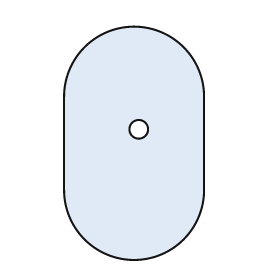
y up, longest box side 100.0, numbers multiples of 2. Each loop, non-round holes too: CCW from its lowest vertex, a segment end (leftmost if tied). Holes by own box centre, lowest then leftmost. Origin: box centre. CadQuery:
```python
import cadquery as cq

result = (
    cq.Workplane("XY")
    .moveTo(-30.0, -20.0)
    .threePointArc((0.0, -50.0), (30.0, -20.0))
    .lineTo(30.0, 20.0)
    .threePointArc((0.0, 50.0), (-30.0, 20.0))
    .close()
    .moveTo(2.0, 6.0)
    .circle(4.0)
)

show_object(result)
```